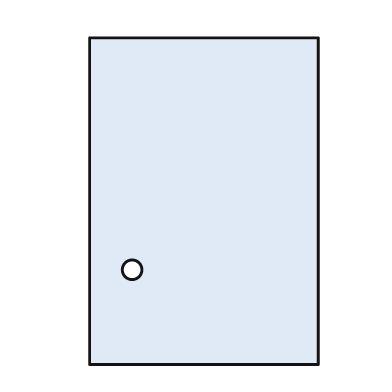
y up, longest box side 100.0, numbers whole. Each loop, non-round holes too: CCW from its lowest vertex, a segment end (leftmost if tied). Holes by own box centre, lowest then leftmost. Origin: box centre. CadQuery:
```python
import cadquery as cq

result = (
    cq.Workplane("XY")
    .moveTo(-35.0, -50.0)
    .lineTo(35.0, -50.0)
    .lineTo(35.0, 50.0)
    .lineTo(-35.0, 50.0)
    .close()
    .moveTo(-22.0, -21.0)
    .circle(3.0)
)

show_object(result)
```